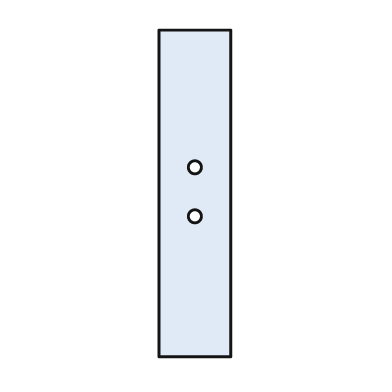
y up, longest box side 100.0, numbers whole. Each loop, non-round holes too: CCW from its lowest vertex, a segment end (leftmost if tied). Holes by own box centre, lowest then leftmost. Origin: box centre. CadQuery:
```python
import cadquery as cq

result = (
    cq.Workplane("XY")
    .moveTo(-11.0, -50.0)
    .lineTo(11.0, -50.0)
    .lineTo(11.0, 50.0)
    .lineTo(-11.0, 50.0)
    .close()
    .moveTo(0.0, -7.0)
    .circle(2.0)
    .moveTo(0.0, 8.0)
    .circle(2.0)
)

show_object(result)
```